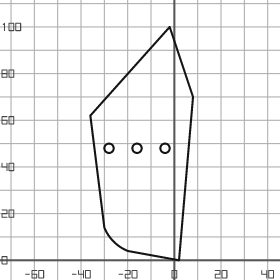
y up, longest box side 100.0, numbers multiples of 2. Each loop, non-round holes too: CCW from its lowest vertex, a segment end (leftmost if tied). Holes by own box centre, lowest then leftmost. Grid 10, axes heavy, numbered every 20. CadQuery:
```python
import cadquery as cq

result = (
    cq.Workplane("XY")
    .moveTo(2.0, 0.0)
    .lineTo(8.0, 70.0)
    .lineTo(-2.0, 100.0)
    .lineTo(-36.0, 62.0)
    .lineTo(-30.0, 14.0)
    .threePointArc((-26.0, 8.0), (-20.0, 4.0))
    .close()
    .moveTo(-28.0, 48.0)
    .circle(2.0)
    .moveTo(-16.0, 48.0)
    .circle(2.0)
    .moveTo(-4.0, 48.0)
    .circle(2.0)
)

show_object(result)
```